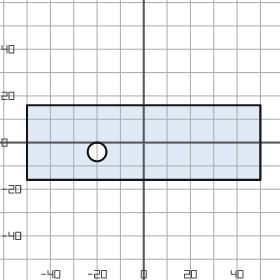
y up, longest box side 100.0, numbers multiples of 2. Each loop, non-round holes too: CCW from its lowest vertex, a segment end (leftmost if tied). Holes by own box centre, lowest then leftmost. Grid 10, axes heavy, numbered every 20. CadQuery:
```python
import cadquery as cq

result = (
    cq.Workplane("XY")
    .moveTo(-50.0, -16.0)
    .lineTo(50.0, -16.0)
    .lineTo(50.0, 16.0)
    .lineTo(-50.0, 16.0)
    .close()
    .moveTo(-20.0, -4.0)
    .circle(4.0)
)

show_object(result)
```